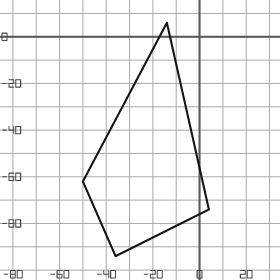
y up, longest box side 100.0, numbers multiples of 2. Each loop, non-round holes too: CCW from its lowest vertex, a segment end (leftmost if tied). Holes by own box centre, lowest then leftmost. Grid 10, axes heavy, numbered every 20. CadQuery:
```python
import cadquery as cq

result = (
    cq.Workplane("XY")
    .moveTo(-36.0, -94.0)
    .lineTo(4.0, -74.0)
    .lineTo(-14.0, 6.0)
    .lineTo(-50.0, -62.0)
    .close()
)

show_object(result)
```